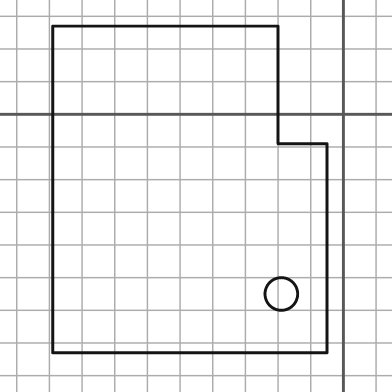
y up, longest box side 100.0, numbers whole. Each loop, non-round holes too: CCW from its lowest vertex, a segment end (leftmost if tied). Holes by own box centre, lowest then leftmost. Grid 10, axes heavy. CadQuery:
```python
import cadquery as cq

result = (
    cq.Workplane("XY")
    .moveTo(-89.0, -73.0)
    .lineTo(-5.0, -73.0)
    .lineTo(-5.0, -9.0)
    .lineTo(-20.0, -9.0)
    .lineTo(-20.0, 27.0)
    .lineTo(-89.0, 27.0)
    .close()
    .moveTo(-19.0, -55.0)
    .circle(5.0)
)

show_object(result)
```